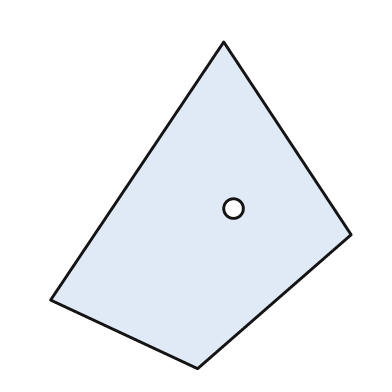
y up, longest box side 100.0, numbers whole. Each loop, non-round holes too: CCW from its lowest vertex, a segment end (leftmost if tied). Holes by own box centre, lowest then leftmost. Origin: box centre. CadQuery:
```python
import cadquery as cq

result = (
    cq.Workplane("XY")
    .moveTo(-1.0, -50.0)
    .lineTo(46.0, -9.0)
    .lineTo(7.0, 50.0)
    .lineTo(-46.0, -29.0)
    .close()
    .moveTo(10.0, -1.0)
    .circle(3.0)
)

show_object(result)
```